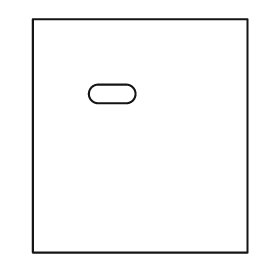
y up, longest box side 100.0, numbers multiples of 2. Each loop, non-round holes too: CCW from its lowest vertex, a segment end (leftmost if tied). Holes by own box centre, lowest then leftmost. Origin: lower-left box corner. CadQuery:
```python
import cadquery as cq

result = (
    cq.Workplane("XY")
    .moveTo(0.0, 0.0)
    .lineTo(92.0, 0.0)
    .lineTo(92.0, 100.0)
    .lineTo(0.0, 100.0)
    .close()
    .moveTo(28.0, 64.0)
    .lineTo(40.0, 64.0)
    .threePointArc((44.0, 68.0), (40.0, 72.0))
    .lineTo(28.0, 72.0)
    .threePointArc((24.0, 68.0), (28.0, 64.0))
    .close()
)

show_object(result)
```